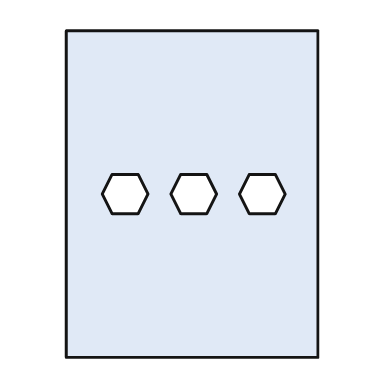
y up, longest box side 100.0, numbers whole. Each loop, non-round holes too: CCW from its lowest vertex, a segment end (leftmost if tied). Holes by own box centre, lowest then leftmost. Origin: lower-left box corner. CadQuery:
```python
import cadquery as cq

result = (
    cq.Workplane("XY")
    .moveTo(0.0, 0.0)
    .lineTo(77.0, 0.0)
    .lineTo(77.0, 100.0)
    .lineTo(0.0, 100.0)
    .close()
    .moveTo(14.0, 44.0)
    .lineTo(22.0, 44.0)
    .lineTo(25.0, 50.0)
    .lineTo(22.0, 56.0)
    .lineTo(14.0, 56.0)
    .lineTo(11.0, 50.0)
    .close()
    .moveTo(35.0, 44.0)
    .lineTo(43.0, 44.0)
    .lineTo(46.0, 50.0)
    .lineTo(43.0, 56.0)
    .lineTo(35.0, 56.0)
    .lineTo(32.0, 50.0)
    .close()
    .moveTo(56.0, 44.0)
    .lineTo(64.0, 44.0)
    .lineTo(67.0, 50.0)
    .lineTo(64.0, 56.0)
    .lineTo(56.0, 56.0)
    .lineTo(53.0, 50.0)
    .close()
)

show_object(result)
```